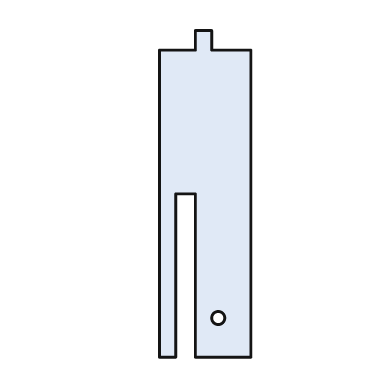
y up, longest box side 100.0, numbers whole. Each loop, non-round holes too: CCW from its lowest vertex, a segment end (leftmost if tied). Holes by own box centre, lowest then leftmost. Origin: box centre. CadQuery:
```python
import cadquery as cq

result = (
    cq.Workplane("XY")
    .moveTo(-14.0, -50.0)
    .lineTo(-9.0, -50.0)
    .lineTo(-9.0, 0.0)
    .lineTo(-3.0, 0.0)
    .lineTo(-3.0, -50.0)
    .lineTo(14.0, -50.0)
    .lineTo(14.0, 44.0)
    .lineTo(2.0, 44.0)
    .lineTo(2.0, 50.0)
    .lineTo(-3.0, 50.0)
    .lineTo(-3.0, 44.0)
    .lineTo(-14.0, 44.0)
    .close()
    .moveTo(4.0, -38.0)
    .circle(2.0)
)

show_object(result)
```